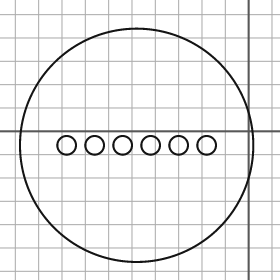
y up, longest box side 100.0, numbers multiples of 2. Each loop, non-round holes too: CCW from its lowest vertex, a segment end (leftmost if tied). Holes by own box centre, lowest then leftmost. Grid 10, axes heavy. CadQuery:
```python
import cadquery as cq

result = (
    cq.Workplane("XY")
    .moveTo(-48.0, -6.0)
    .circle(50.0)
    .moveTo(-78.0, -6.0)
    .circle(4.0)
    .moveTo(-66.0, -6.0)
    .circle(4.0)
    .moveTo(-54.0, -6.0)
    .circle(4.0)
    .moveTo(-42.0, -6.0)
    .circle(4.0)
    .moveTo(-30.0, -6.0)
    .circle(4.0)
    .moveTo(-18.0, -6.0)
    .circle(4.0)
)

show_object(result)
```